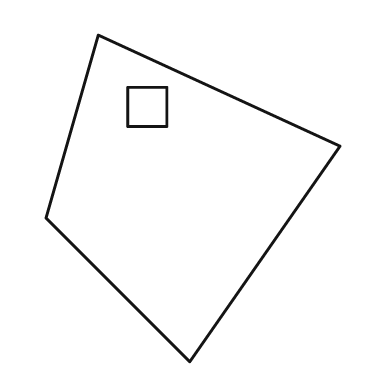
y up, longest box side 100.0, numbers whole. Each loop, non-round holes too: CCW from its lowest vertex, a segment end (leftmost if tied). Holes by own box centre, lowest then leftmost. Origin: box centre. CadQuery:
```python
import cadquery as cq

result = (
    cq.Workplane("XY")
    .moveTo(-1.0, -50.0)
    .lineTo(45.0, 16.0)
    .lineTo(-29.0, 50.0)
    .lineTo(-45.0, -6.0)
    .close()
    .moveTo(-20.0, 22.0)
    .lineTo(-8.0, 22.0)
    .lineTo(-8.0, 34.0)
    .lineTo(-20.0, 34.0)
    .close()
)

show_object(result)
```